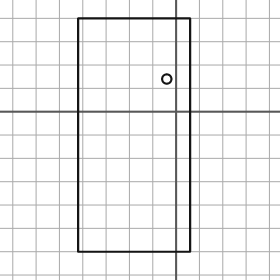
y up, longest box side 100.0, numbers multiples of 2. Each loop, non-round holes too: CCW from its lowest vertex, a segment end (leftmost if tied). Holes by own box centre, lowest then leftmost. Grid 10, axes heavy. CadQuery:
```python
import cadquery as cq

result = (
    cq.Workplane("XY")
    .moveTo(-42.0, -60.0)
    .lineTo(6.0, -60.0)
    .lineTo(6.0, 40.0)
    .lineTo(-42.0, 40.0)
    .close()
    .moveTo(-4.0, 14.0)
    .circle(2.0)
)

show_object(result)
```